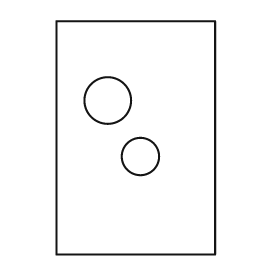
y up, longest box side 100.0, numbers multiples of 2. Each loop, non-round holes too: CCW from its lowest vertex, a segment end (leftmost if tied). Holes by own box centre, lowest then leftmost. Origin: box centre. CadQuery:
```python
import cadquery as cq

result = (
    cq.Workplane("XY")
    .moveTo(-34.0, -50.0)
    .lineTo(34.0, -50.0)
    .lineTo(34.0, 50.0)
    .lineTo(-34.0, 50.0)
    .close()
    .moveTo(2.0, -8.0)
    .circle(8.0)
    .moveTo(-12.0, 16.0)
    .circle(10.0)
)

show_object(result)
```